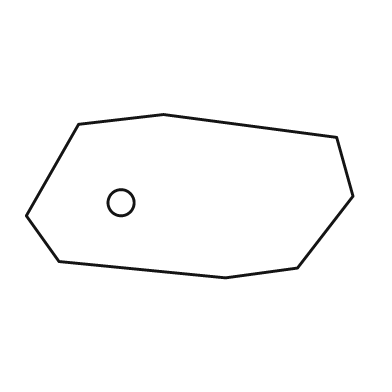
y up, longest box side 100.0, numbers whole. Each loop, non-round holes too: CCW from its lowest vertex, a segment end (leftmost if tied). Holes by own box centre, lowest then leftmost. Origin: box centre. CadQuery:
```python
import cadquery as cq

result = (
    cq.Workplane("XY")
    .moveTo(11.0, -25.0)
    .lineTo(33.0, -22.0)
    .lineTo(50.0, 0.0)
    .lineTo(45.0, 18.0)
    .lineTo(-8.0, 25.0)
    .lineTo(-34.0, 22.0)
    .lineTo(-50.0, -6.0)
    .lineTo(-40.0, -20.0)
    .close()
    .moveTo(-21.0, -2.0)
    .circle(4.0)
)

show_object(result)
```